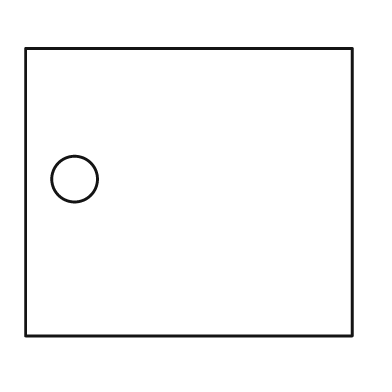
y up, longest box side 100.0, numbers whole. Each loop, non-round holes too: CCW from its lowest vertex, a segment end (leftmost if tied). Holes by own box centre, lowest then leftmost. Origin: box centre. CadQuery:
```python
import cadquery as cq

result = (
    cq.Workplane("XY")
    .moveTo(-50.0, -44.0)
    .lineTo(50.0, -44.0)
    .lineTo(50.0, 44.0)
    .lineTo(-50.0, 44.0)
    .close()
    .moveTo(-35.0, 4.0)
    .circle(7.0)
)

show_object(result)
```